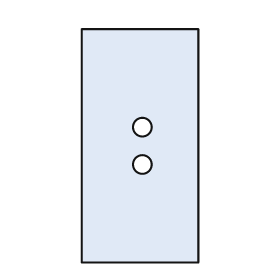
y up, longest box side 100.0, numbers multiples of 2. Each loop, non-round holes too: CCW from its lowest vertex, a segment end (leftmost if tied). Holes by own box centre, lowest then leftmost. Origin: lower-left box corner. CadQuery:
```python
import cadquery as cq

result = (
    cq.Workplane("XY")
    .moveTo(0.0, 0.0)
    .lineTo(50.0, 0.0)
    .lineTo(50.0, 100.0)
    .lineTo(0.0, 100.0)
    .close()
    .moveTo(26.0, 42.0)
    .circle(4.0)
    .moveTo(26.0, 58.0)
    .circle(4.0)
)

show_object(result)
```